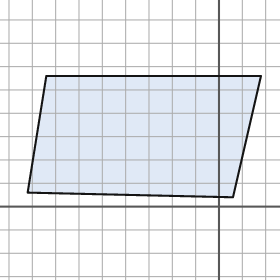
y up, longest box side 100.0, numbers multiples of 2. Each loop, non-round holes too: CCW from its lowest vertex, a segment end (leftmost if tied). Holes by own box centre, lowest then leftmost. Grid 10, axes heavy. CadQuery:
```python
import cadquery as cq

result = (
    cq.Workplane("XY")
    .moveTo(6.0, 4.0)
    .lineTo(18.0, 56.0)
    .lineTo(-74.0, 56.0)
    .lineTo(-82.0, 6.0)
    .close()
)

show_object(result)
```